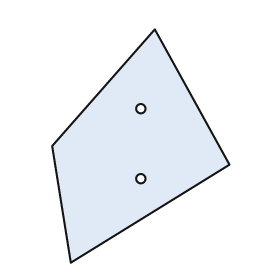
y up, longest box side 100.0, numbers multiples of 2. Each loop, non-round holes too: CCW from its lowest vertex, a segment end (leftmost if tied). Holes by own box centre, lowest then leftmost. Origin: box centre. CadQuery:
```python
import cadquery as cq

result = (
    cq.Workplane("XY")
    .moveTo(-30.0, -50.0)
    .lineTo(38.0, -8.0)
    .lineTo(6.0, 50.0)
    .lineTo(-38.0, 0.0)
    .close()
    .moveTo(0.0, -14.0)
    .circle(2.0)
    .moveTo(0.0, 16.0)
    .circle(2.0)
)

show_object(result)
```